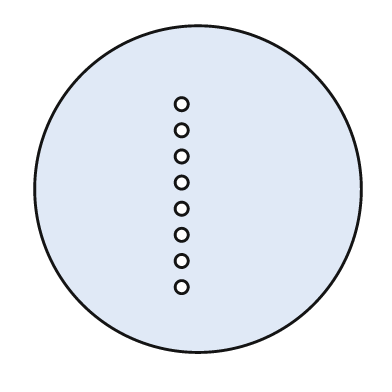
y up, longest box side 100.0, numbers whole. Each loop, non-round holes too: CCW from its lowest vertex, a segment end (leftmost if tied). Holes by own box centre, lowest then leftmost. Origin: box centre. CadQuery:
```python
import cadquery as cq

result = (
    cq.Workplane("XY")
    .moveTo(0.0, 0.0)
    .circle(50.0)
    .moveTo(-5.0, -30.0)
    .circle(2.0)
    .moveTo(-5.0, -22.0)
    .circle(2.0)
    .moveTo(-5.0, -14.0)
    .circle(2.0)
    .moveTo(-5.0, -6.0)
    .circle(2.0)
    .moveTo(-5.0, 2.0)
    .circle(2.0)
    .moveTo(-5.0, 10.0)
    .circle(2.0)
    .moveTo(-5.0, 18.0)
    .circle(2.0)
    .moveTo(-5.0, 26.0)
    .circle(2.0)
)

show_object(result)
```